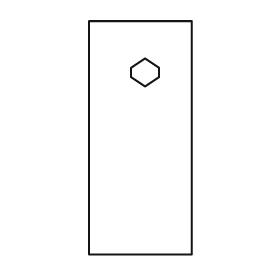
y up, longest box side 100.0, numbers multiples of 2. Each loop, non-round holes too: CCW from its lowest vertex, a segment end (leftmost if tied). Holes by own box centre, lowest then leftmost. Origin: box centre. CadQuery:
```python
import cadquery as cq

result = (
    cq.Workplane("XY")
    .moveTo(-22.0, -50.0)
    .lineTo(22.0, -50.0)
    .lineTo(22.0, 50.0)
    .lineTo(-22.0, 50.0)
    .close()
    .moveTo(2.0, 22.0)
    .lineTo(8.0, 26.0)
    .lineTo(8.0, 30.0)
    .lineTo(2.0, 34.0)
    .lineTo(-4.0, 30.0)
    .lineTo(-4.0, 26.0)
    .close()
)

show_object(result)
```